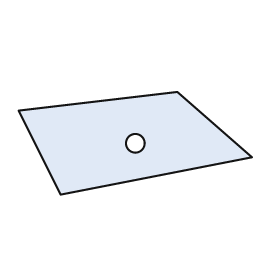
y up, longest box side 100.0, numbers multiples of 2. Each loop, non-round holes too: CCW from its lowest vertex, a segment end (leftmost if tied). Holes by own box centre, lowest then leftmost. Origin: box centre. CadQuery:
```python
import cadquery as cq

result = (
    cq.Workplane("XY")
    .moveTo(-32.0, -22.0)
    .lineTo(50.0, -6.0)
    .lineTo(18.0, 22.0)
    .lineTo(-50.0, 14.0)
    .close()
    .moveTo(0.0, 0.0)
    .circle(4.0)
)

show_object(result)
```